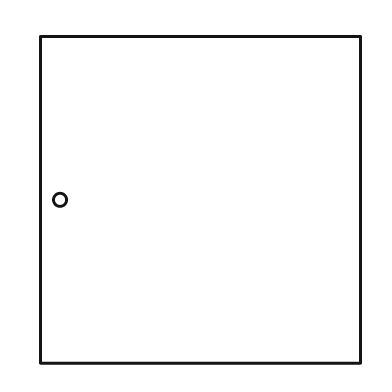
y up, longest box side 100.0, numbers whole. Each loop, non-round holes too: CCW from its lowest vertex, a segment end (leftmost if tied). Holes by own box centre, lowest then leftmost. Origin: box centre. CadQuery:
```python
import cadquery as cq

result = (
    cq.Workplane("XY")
    .moveTo(-49.0, -50.0)
    .lineTo(49.0, -50.0)
    .lineTo(49.0, 50.0)
    .lineTo(-49.0, 50.0)
    .close()
    .moveTo(-43.0, 0.0)
    .circle(2.0)
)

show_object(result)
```